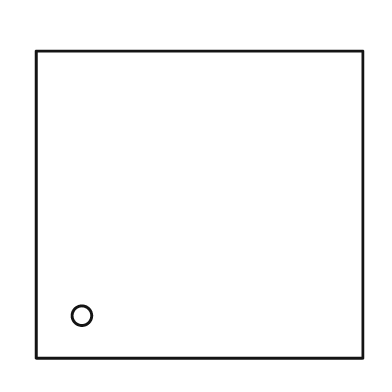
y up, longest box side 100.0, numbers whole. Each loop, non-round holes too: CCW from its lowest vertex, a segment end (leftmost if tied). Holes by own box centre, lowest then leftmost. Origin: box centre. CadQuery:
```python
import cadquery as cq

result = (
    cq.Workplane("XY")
    .moveTo(-50.0, -47.0)
    .lineTo(50.0, -47.0)
    .lineTo(50.0, 47.0)
    .lineTo(-50.0, 47.0)
    .close()
    .moveTo(-36.0, -34.0)
    .circle(3.0)
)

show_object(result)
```